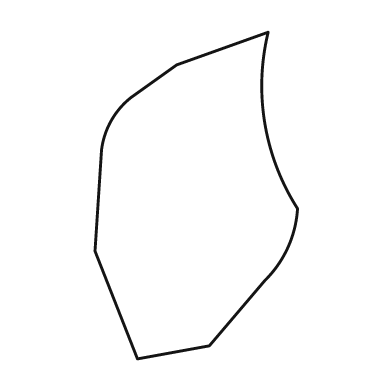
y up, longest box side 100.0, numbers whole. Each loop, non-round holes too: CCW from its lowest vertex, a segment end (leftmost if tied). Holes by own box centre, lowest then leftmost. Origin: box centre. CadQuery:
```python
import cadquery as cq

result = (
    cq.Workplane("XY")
    .moveTo(-18.0, -50.0)
    .lineTo(4.0, -46.0)
    .lineTo(21.0, -26.0)
    .threePointArc((28.0, -16.0), (31.0, -4.0))
    .threePointArc((21.0, 22.0), (22.0, 50.0))
    .lineTo(-6.0, 40.0)
    .lineTo(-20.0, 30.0)
    .threePointArc((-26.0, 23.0), (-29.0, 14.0))
    .lineTo(-31.0, -17.0)
    .close()
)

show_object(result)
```